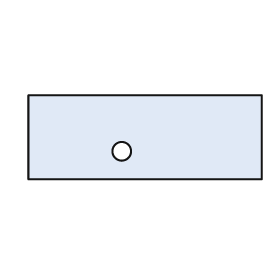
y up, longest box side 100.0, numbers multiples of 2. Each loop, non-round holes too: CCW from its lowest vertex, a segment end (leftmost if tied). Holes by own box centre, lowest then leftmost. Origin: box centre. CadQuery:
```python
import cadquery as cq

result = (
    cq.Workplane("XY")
    .moveTo(-50.0, -18.0)
    .lineTo(50.0, -18.0)
    .lineTo(50.0, 18.0)
    .lineTo(-50.0, 18.0)
    .close()
    .moveTo(-10.0, -6.0)
    .circle(4.0)
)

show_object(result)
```